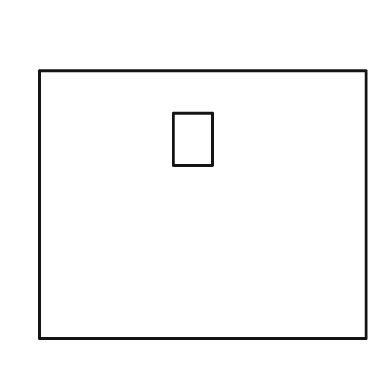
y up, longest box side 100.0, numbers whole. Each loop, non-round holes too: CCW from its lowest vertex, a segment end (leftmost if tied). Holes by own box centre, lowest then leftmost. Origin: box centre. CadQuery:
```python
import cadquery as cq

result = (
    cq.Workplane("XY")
    .moveTo(-50.0, -41.0)
    .lineTo(50.0, -41.0)
    .lineTo(50.0, 41.0)
    .lineTo(-50.0, 41.0)
    .close()
    .moveTo(-9.0, 12.0)
    .lineTo(3.0, 12.0)
    .lineTo(3.0, 28.0)
    .lineTo(-9.0, 28.0)
    .close()
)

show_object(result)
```